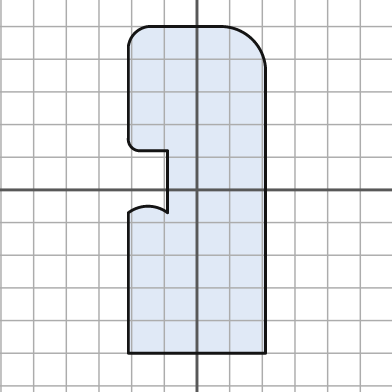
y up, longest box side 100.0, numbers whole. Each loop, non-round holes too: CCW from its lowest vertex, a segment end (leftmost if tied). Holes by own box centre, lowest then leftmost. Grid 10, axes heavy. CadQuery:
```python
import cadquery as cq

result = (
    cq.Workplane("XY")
    .moveTo(-21.0, -50.0)
    .lineTo(21.0, -50.0)
    .lineTo(21.0, 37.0)
    .threePointArc((17.0, 46.0), (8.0, 50.0))
    .lineTo(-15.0, 50.0)
    .threePointArc((-19.0, 48.0), (-21.0, 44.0))
    .lineTo(-21.0, 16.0)
    .threePointArc((-20.0, 13.0), (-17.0, 12.0))
    .lineTo(-9.0, 12.0)
    .lineTo(-9.0, -7.0)
    .threePointArc((-15.0, -5.0), (-21.0, -7.0))
    .close()
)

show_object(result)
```